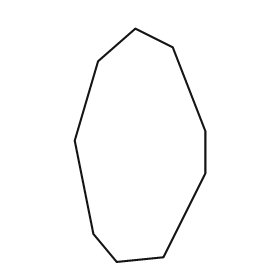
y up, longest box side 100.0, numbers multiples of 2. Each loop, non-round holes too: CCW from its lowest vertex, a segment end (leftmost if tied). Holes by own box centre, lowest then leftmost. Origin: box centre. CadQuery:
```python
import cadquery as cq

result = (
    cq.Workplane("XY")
    .moveTo(-10.0, -50.0)
    .lineTo(10.0, -48.0)
    .lineTo(28.0, -12.0)
    .lineTo(28.0, 6.0)
    .lineTo(14.0, 42.0)
    .lineTo(-2.0, 50.0)
    .lineTo(-18.0, 36.0)
    .lineTo(-28.0, 2.0)
    .lineTo(-20.0, -38.0)
    .close()
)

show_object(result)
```